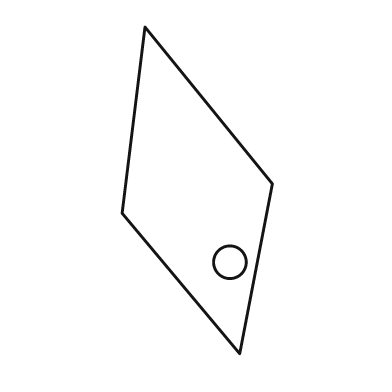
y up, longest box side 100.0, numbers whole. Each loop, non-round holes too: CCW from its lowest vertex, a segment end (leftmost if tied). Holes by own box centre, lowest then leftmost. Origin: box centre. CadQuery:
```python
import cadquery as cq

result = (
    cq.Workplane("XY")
    .moveTo(13.0, -50.0)
    .lineTo(23.0, 2.0)
    .lineTo(-16.0, 50.0)
    .lineTo(-23.0, -7.0)
    .close()
    .moveTo(10.0, -22.0)
    .circle(5.0)
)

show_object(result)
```